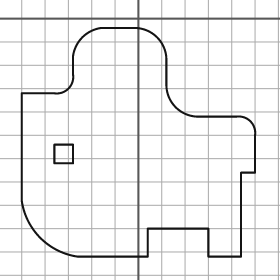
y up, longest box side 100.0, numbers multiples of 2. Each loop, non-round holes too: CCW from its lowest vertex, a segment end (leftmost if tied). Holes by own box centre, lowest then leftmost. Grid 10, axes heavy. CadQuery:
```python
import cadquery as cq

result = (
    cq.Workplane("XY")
    .moveTo(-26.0, -102.0)
    .lineTo(4.0, -102.0)
    .lineTo(4.0, -90.0)
    .lineTo(30.0, -90.0)
    .lineTo(30.0, -102.0)
    .lineTo(44.0, -102.0)
    .lineTo(44.0, -66.0)
    .lineTo(50.0, -66.0)
    .lineTo(50.0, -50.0)
    .threePointArc((48.0, -44.0), (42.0, -42.0))
    .lineTo(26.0, -42.0)
    .threePointArc((16.0, -38.0), (12.0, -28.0))
    .lineTo(12.0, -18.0)
    .threePointArc((8.0, -8.0), (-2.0, -4.0))
    .lineTo(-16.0, -4.0)
    .threePointArc((-24.0, -8.0), (-28.0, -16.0))
    .lineTo(-28.0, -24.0)
    .threePointArc((-30.0, -30.0), (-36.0, -32.0))
    .lineTo(-50.0, -32.0)
    .lineTo(-50.0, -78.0)
    .threePointArc((-42.0, -94.0), (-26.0, -102.0))
    .close()
    .moveTo(-36.0, -62.0)
    .lineTo(-28.0, -62.0)
    .lineTo(-28.0, -54.0)
    .lineTo(-36.0, -54.0)
    .close()
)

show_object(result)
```